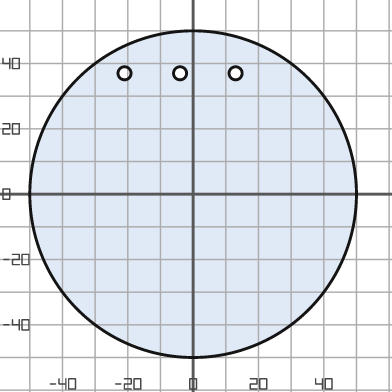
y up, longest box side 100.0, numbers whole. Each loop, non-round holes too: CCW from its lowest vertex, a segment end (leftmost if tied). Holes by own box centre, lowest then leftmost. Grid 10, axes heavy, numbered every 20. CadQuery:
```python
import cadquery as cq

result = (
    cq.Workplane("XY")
    .moveTo(0.0, 0.0)
    .circle(50.0)
    .moveTo(-21.0, 37.0)
    .circle(2.0)
    .moveTo(-4.0, 37.0)
    .circle(2.0)
    .moveTo(13.0, 37.0)
    .circle(2.0)
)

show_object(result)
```